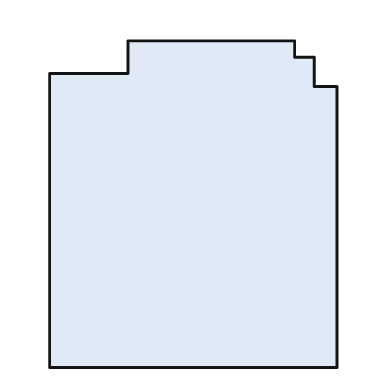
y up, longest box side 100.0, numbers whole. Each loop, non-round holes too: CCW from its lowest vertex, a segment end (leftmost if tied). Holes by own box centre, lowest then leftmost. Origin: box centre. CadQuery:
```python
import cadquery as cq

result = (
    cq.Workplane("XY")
    .moveTo(-44.0, -50.0)
    .lineTo(44.0, -50.0)
    .lineTo(44.0, 36.0)
    .lineTo(37.0, 36.0)
    .lineTo(37.0, 45.0)
    .lineTo(31.0, 45.0)
    .lineTo(31.0, 50.0)
    .lineTo(-20.0, 50.0)
    .lineTo(-20.0, 40.0)
    .lineTo(-44.0, 40.0)
    .close()
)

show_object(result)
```